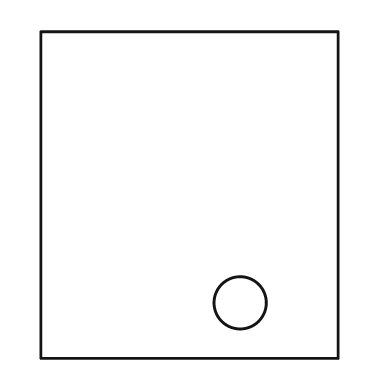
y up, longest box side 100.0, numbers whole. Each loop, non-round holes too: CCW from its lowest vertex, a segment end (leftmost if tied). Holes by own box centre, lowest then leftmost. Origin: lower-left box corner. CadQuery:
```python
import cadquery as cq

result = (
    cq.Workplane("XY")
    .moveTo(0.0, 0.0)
    .lineTo(91.0, 0.0)
    .lineTo(91.0, 100.0)
    .lineTo(0.0, 100.0)
    .close()
    .moveTo(61.0, 17.0)
    .circle(8.0)
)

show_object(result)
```